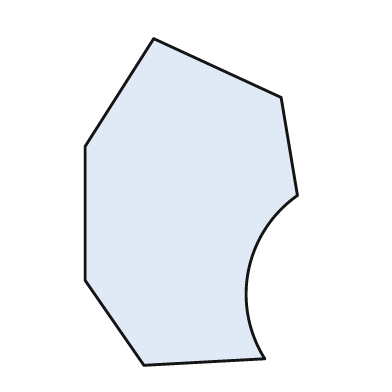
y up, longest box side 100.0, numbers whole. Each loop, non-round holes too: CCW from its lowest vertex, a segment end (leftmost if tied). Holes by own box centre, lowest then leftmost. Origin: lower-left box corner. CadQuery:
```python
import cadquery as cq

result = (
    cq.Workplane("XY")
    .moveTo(18.0, 0.0)
    .lineTo(55.0, 2.0)
    .threePointArc((50.0, 29.0), (65.0, 52.0))
    .lineTo(60.0, 82.0)
    .lineTo(21.0, 100.0)
    .lineTo(0.0, 67.0)
    .lineTo(0.0, 26.0)
    .close()
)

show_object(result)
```